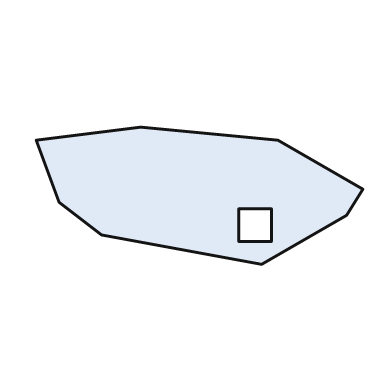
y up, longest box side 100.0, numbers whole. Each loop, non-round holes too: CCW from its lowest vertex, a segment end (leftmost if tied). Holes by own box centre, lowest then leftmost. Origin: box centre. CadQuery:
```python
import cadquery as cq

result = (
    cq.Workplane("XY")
    .moveTo(19.0, -21.0)
    .lineTo(45.0, -6.0)
    .lineTo(50.0, 2.0)
    .lineTo(24.0, 17.0)
    .lineTo(-18.0, 21.0)
    .lineTo(-50.0, 17.0)
    .lineTo(-43.0, -2.0)
    .lineTo(-30.0, -12.0)
    .close()
    .moveTo(12.0, -14.0)
    .lineTo(22.0, -14.0)
    .lineTo(22.0, -4.0)
    .lineTo(12.0, -4.0)
    .close()
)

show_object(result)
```